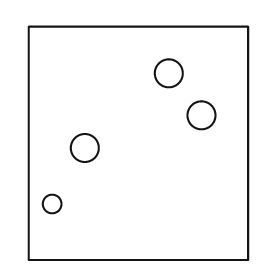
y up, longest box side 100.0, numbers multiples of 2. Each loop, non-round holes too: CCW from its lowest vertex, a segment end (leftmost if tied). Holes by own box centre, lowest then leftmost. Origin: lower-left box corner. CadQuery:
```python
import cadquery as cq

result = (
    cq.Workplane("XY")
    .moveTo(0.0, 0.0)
    .lineTo(94.0, 0.0)
    .lineTo(94.0, 100.0)
    .lineTo(0.0, 100.0)
    .close()
    .moveTo(10.0, 24.0)
    .circle(4.0)
    .moveTo(24.0, 48.0)
    .circle(6.0)
    .moveTo(74.0, 62.0)
    .circle(6.0)
    .moveTo(60.0, 80.0)
    .circle(6.0)
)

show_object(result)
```